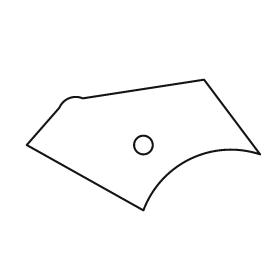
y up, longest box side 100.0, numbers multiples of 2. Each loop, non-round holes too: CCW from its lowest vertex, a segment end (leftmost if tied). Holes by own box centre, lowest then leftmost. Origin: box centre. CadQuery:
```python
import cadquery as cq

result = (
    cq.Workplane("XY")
    .moveTo(0.0, -28.0)
    .threePointArc((20.0, -6.0), (50.0, -4.0))
    .lineTo(26.0, 28.0)
    .lineTo(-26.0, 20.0)
    .threePointArc((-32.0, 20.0), (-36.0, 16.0))
    .lineTo(-50.0, 0.0)
    .close()
    .moveTo(0.0, 0.0)
    .circle(4.0)
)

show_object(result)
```